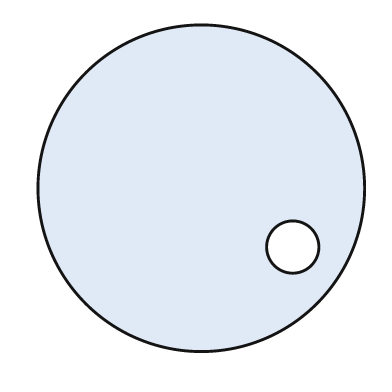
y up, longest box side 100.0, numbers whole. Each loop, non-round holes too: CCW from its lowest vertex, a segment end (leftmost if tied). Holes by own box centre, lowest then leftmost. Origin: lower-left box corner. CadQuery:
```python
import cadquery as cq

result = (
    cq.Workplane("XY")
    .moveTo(50.0, 50.0)
    .circle(50.0)
    .moveTo(78.0, 32.0)
    .circle(8.0)
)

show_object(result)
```